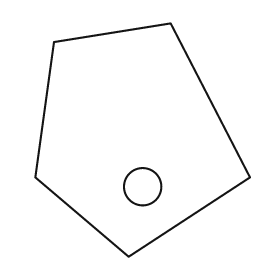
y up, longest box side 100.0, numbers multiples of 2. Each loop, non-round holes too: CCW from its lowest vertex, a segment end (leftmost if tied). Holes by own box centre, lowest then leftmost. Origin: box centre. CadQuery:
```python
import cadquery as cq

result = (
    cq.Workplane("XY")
    .moveTo(-6.0, -50.0)
    .lineTo(46.0, -16.0)
    .lineTo(12.0, 50.0)
    .lineTo(-38.0, 42.0)
    .lineTo(-46.0, -16.0)
    .close()
    .moveTo(0.0, -20.0)
    .circle(8.0)
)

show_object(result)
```